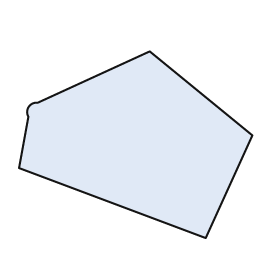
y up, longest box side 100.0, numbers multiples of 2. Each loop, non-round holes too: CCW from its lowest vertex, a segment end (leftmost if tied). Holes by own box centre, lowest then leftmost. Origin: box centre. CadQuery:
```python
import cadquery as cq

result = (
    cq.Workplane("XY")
    .moveTo(30.0, -40.0)
    .lineTo(50.0, 4.0)
    .lineTo(6.0, 40.0)
    .lineTo(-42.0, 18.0)
    .threePointArc((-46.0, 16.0), (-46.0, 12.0))
    .lineTo(-50.0, -10.0)
    .close()
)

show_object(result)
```